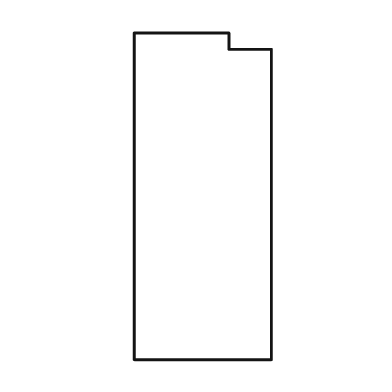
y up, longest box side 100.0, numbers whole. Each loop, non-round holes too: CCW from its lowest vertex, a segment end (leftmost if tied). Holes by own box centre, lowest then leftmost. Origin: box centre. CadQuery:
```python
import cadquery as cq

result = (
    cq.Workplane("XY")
    .moveTo(-21.0, -50.0)
    .lineTo(21.0, -50.0)
    .lineTo(21.0, 45.0)
    .lineTo(8.0, 45.0)
    .lineTo(8.0, 50.0)
    .lineTo(-21.0, 50.0)
    .close()
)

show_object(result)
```